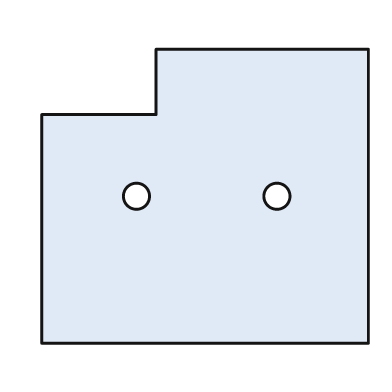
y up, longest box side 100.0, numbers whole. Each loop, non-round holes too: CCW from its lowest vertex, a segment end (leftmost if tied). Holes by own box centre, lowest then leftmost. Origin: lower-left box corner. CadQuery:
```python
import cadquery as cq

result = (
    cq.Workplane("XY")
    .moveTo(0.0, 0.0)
    .lineTo(100.0, 0.0)
    .lineTo(100.0, 90.0)
    .lineTo(35.0, 90.0)
    .lineTo(35.0, 70.0)
    .lineTo(0.0, 70.0)
    .close()
    .moveTo(29.0, 45.0)
    .circle(4.0)
    .moveTo(72.0, 45.0)
    .circle(4.0)
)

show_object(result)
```